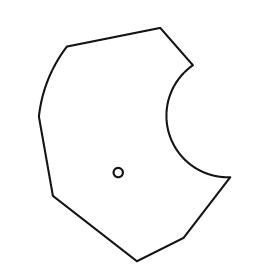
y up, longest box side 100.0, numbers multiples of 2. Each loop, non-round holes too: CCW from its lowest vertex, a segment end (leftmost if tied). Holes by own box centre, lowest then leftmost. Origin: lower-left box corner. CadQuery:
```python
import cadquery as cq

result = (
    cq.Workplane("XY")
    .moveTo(42.0, 0.0)
    .lineTo(62.0, 10.0)
    .lineTo(82.0, 36.0)
    .threePointArc((56.0, 54.0), (66.0, 84.0))
    .lineTo(52.0, 100.0)
    .lineTo(12.0, 92.0)
    .threePointArc((4.0, 78.0), (0.0, 62.0))
    .lineTo(6.0, 28.0)
    .close()
    .moveTo(34.0, 38.0)
    .circle(2.0)
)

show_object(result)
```